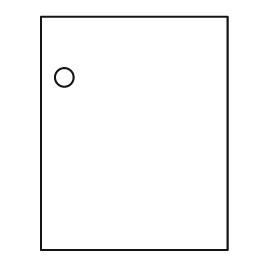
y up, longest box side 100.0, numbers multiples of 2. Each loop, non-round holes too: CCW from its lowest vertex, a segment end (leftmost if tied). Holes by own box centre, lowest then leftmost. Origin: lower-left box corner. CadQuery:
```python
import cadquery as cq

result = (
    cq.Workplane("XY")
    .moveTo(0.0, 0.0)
    .lineTo(80.0, 0.0)
    .lineTo(80.0, 100.0)
    .lineTo(0.0, 100.0)
    .close()
    .moveTo(10.0, 74.0)
    .circle(4.0)
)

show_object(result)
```